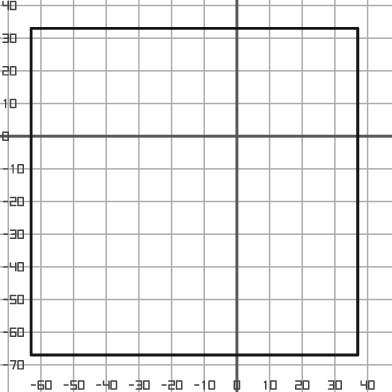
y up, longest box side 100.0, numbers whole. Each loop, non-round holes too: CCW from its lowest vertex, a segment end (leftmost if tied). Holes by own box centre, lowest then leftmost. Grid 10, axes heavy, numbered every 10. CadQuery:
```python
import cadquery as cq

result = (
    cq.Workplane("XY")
    .moveTo(-63.0, -67.0)
    .lineTo(37.0, -67.0)
    .lineTo(37.0, 33.0)
    .lineTo(-63.0, 33.0)
    .close()
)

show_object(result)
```